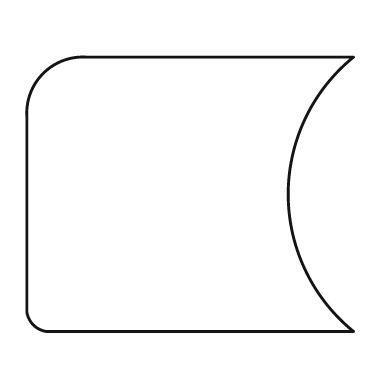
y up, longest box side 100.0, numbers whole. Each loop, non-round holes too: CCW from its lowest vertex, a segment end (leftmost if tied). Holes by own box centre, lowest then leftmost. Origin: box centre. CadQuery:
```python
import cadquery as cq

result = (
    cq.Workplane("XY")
    .moveTo(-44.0, -42.0)
    .lineTo(50.0, -42.0)
    .threePointArc((30.0, 0.0), (50.0, 42.0))
    .lineTo(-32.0, 42.0)
    .threePointArc((-45.0, 37.0), (-50.0, 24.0))
    .lineTo(-50.0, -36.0)
    .threePointArc((-48.0, -40.0), (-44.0, -42.0))
    .close()
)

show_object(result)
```